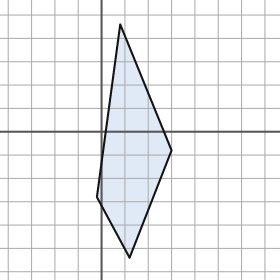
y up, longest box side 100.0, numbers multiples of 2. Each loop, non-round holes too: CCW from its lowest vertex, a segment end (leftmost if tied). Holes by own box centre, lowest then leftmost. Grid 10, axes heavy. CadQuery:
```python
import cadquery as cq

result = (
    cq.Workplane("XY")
    .moveTo(12.0, -54.0)
    .lineTo(30.0, -8.0)
    .lineTo(8.0, 46.0)
    .lineTo(-2.0, -28.0)
    .close()
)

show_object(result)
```